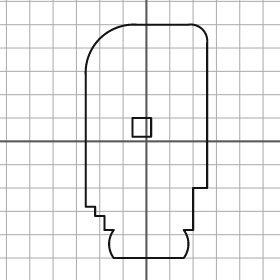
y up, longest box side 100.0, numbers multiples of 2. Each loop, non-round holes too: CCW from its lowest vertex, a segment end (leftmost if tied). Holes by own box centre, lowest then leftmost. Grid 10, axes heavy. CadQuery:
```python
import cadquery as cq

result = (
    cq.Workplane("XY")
    .moveTo(-14.0, -50.0)
    .lineTo(16.0, -50.0)
    .threePointArc((18.0, -44.0), (16.0, -38.0))
    .lineTo(20.0, -38.0)
    .lineTo(20.0, -20.0)
    .lineTo(26.0, -20.0)
    .lineTo(26.0, 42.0)
    .threePointArc((24.0, 48.0), (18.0, 50.0))
    .lineTo(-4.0, 50.0)
    .threePointArc((-20.0, 44.0), (-26.0, 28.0))
    .lineTo(-26.0, -28.0)
    .lineTo(-22.0, -28.0)
    .lineTo(-22.0, -32.0)
    .lineTo(-18.0, -32.0)
    .lineTo(-18.0, -38.0)
    .lineTo(-14.0, -38.0)
    .threePointArc((-16.0, -44.0), (-14.0, -50.0))
    .close()
    .moveTo(-6.0, 2.0)
    .lineTo(2.0, 2.0)
    .lineTo(2.0, 10.0)
    .lineTo(-6.0, 10.0)
    .close()
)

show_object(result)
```